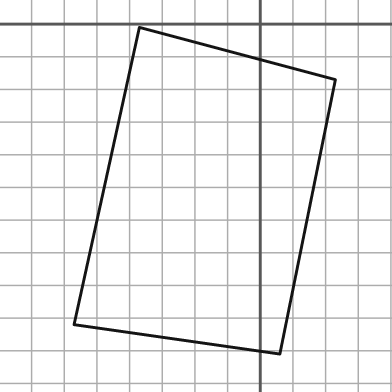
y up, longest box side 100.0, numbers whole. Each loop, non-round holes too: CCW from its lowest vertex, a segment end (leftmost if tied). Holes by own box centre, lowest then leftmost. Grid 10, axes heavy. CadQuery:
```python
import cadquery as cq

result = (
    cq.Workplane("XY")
    .moveTo(6.0, -101.0)
    .lineTo(23.0, -17.0)
    .lineTo(-37.0, -1.0)
    .lineTo(-57.0, -92.0)
    .close()
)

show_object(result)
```